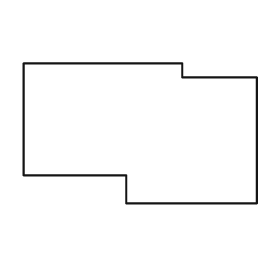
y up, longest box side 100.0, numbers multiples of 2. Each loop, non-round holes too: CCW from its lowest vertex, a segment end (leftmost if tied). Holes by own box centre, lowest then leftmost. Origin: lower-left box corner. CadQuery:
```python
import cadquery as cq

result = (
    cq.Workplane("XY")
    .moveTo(44.0, 0.0)
    .lineTo(100.0, 0.0)
    .lineTo(100.0, 54.0)
    .lineTo(68.0, 54.0)
    .lineTo(68.0, 60.0)
    .lineTo(0.0, 60.0)
    .lineTo(0.0, 12.0)
    .lineTo(44.0, 12.0)
    .close()
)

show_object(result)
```